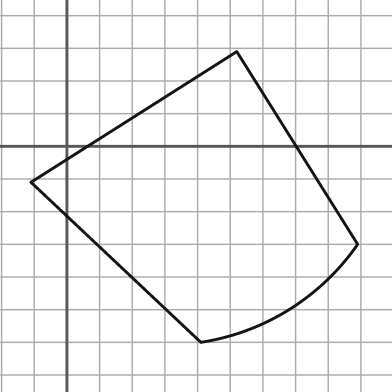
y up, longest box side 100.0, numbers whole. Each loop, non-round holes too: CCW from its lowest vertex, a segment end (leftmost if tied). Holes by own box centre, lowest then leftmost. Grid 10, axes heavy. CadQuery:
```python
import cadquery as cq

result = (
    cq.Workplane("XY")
    .moveTo(41.0, -60.0)
    .threePointArc((68.0, -50.0), (89.0, -30.0))
    .lineTo(52.0, 29.0)
    .lineTo(-11.0, -11.0)
    .close()
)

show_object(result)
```